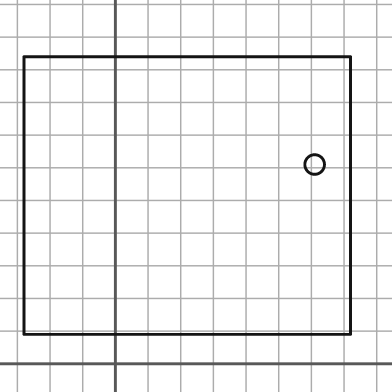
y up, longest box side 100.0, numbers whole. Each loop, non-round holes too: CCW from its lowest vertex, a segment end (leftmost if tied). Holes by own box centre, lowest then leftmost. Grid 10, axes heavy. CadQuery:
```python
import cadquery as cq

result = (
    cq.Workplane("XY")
    .moveTo(-28.0, 9.0)
    .lineTo(72.0, 9.0)
    .lineTo(72.0, 94.0)
    .lineTo(-28.0, 94.0)
    .close()
    .moveTo(61.0, 61.0)
    .circle(3.0)
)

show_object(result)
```